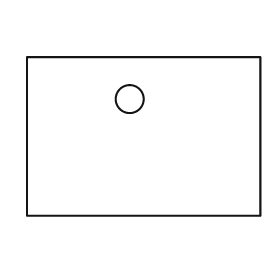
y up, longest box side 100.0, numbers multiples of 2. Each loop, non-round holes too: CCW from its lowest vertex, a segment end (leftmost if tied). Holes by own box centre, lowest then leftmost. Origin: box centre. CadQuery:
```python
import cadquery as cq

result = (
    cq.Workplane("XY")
    .moveTo(-50.0, -34.0)
    .lineTo(50.0, -34.0)
    .lineTo(50.0, 34.0)
    .lineTo(-50.0, 34.0)
    .close()
    .moveTo(-6.0, 16.0)
    .circle(6.0)
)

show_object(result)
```